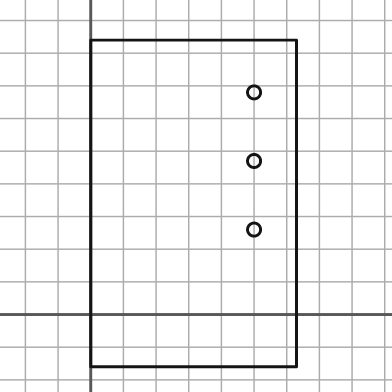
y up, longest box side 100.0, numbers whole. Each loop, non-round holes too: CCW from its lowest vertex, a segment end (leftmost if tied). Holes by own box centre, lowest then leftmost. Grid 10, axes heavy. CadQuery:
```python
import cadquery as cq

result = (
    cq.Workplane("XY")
    .moveTo(0.0, -16.0)
    .lineTo(63.0, -16.0)
    .lineTo(63.0, 84.0)
    .lineTo(0.0, 84.0)
    .close()
    .moveTo(50.0, 26.0)
    .circle(2.0)
    .moveTo(50.0, 47.0)
    .circle(2.0)
    .moveTo(50.0, 68.0)
    .circle(2.0)
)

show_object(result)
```